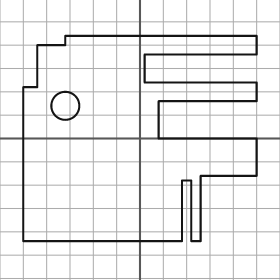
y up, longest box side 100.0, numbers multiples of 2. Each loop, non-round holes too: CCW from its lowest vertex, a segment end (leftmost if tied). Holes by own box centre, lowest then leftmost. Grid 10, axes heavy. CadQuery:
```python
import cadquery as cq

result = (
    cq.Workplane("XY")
    .moveTo(-50.0, -44.0)
    .lineTo(18.0, -44.0)
    .lineTo(18.0, -18.0)
    .lineTo(22.0, -18.0)
    .lineTo(22.0, -44.0)
    .lineTo(26.0, -44.0)
    .lineTo(26.0, -16.0)
    .lineTo(50.0, -16.0)
    .lineTo(50.0, 0.0)
    .lineTo(8.0, 0.0)
    .lineTo(8.0, 16.0)
    .lineTo(50.0, 16.0)
    .lineTo(50.0, 24.0)
    .lineTo(2.0, 24.0)
    .lineTo(2.0, 36.0)
    .lineTo(50.0, 36.0)
    .lineTo(50.0, 44.0)
    .lineTo(-32.0, 44.0)
    .lineTo(-32.0, 40.0)
    .lineTo(-44.0, 40.0)
    .lineTo(-44.0, 22.0)
    .lineTo(-50.0, 22.0)
    .close()
    .moveTo(-32.0, 14.0)
    .circle(6.0)
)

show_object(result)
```